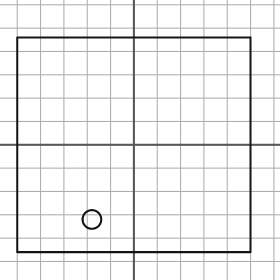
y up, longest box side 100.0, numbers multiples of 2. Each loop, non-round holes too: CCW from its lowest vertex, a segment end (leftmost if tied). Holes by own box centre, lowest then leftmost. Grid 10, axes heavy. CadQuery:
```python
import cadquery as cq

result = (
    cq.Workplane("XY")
    .moveTo(-50.0, -46.0)
    .lineTo(50.0, -46.0)
    .lineTo(50.0, 46.0)
    .lineTo(-50.0, 46.0)
    .close()
    .moveTo(-18.0, -32.0)
    .circle(4.0)
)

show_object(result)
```